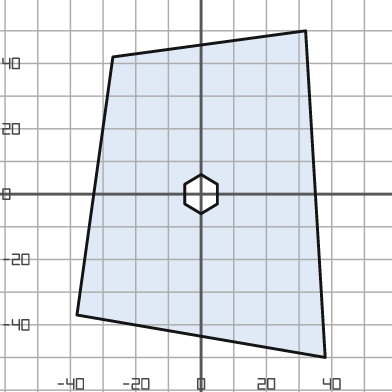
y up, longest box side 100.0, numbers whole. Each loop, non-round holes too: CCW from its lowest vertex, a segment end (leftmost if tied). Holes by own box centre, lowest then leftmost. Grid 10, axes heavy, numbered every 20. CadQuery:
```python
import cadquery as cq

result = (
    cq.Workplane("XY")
    .moveTo(38.0, -50.0)
    .lineTo(32.0, 50.0)
    .lineTo(-27.0, 42.0)
    .lineTo(-38.0, -37.0)
    .close()
    .moveTo(0.0, -6.0)
    .lineTo(5.0, -3.0)
    .lineTo(5.0, 3.0)
    .lineTo(0.0, 6.0)
    .lineTo(-5.0, 3.0)
    .lineTo(-5.0, -3.0)
    .close()
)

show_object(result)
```